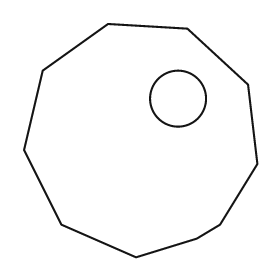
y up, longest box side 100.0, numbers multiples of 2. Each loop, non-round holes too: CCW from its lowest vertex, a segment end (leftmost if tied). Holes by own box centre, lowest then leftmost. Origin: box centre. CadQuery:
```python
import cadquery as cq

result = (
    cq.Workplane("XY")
    .moveTo(-2.0, -50.0)
    .lineTo(24.0, -42.0)
    .lineTo(34.0, -36.0)
    .lineTo(50.0, -10.0)
    .lineTo(46.0, 24.0)
    .lineTo(20.0, 48.0)
    .lineTo(-14.0, 50.0)
    .lineTo(-42.0, 30.0)
    .lineTo(-50.0, -4.0)
    .lineTo(-34.0, -36.0)
    .close()
    .moveTo(16.0, 18.0)
    .circle(12.0)
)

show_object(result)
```